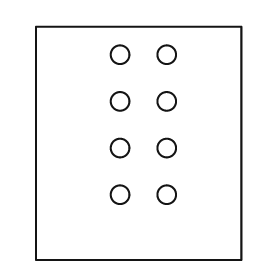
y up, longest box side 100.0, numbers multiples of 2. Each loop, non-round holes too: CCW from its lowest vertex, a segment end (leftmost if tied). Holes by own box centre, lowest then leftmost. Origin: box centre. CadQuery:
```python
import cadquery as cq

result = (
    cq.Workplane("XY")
    .moveTo(-44.0, -50.0)
    .lineTo(44.0, -50.0)
    .lineTo(44.0, 50.0)
    .lineTo(-44.0, 50.0)
    .close()
    .moveTo(-8.0, -22.0)
    .circle(4.0)
    .moveTo(12.0, -22.0)
    .circle(4.0)
    .moveTo(-8.0, -2.0)
    .circle(4.0)
    .moveTo(12.0, -2.0)
    .circle(4.0)
    .moveTo(-8.0, 18.0)
    .circle(4.0)
    .moveTo(12.0, 18.0)
    .circle(4.0)
    .moveTo(-8.0, 38.0)
    .circle(4.0)
    .moveTo(12.0, 38.0)
    .circle(4.0)
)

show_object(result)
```